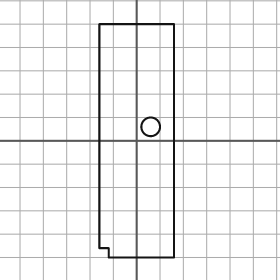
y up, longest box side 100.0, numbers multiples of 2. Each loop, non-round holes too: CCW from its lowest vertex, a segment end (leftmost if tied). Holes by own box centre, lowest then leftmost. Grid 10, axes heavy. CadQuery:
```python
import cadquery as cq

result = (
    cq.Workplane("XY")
    .moveTo(-12.0, -50.0)
    .lineTo(16.0, -50.0)
    .lineTo(16.0, 50.0)
    .lineTo(-16.0, 50.0)
    .lineTo(-16.0, -46.0)
    .lineTo(-12.0, -46.0)
    .close()
    .moveTo(6.0, 6.0)
    .circle(4.0)
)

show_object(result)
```